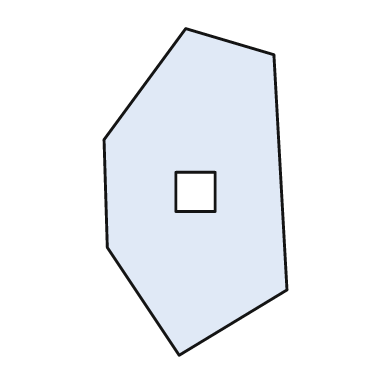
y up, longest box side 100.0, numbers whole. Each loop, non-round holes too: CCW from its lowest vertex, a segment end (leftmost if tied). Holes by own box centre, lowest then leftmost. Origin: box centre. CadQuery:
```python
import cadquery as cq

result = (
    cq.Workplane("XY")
    .moveTo(-5.0, -50.0)
    .lineTo(28.0, -30.0)
    .lineTo(24.0, 42.0)
    .lineTo(-3.0, 50.0)
    .lineTo(-28.0, 16.0)
    .lineTo(-27.0, -17.0)
    .close()
    .moveTo(-6.0, -6.0)
    .lineTo(6.0, -6.0)
    .lineTo(6.0, 6.0)
    .lineTo(-6.0, 6.0)
    .close()
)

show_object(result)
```